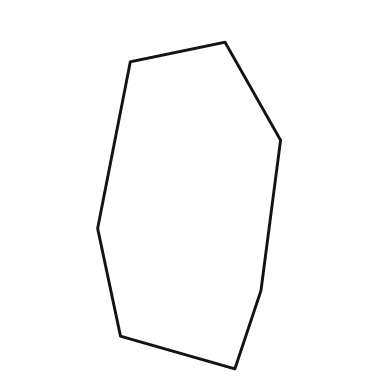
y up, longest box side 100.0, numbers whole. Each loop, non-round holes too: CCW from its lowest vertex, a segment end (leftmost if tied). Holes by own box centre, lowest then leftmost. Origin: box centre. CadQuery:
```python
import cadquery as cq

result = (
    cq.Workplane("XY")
    .moveTo(14.0, -50.0)
    .lineTo(22.0, -26.0)
    .lineTo(28.0, 20.0)
    .lineTo(11.0, 50.0)
    .lineTo(-18.0, 44.0)
    .lineTo(-28.0, -7.0)
    .lineTo(-21.0, -40.0)
    .close()
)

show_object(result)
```